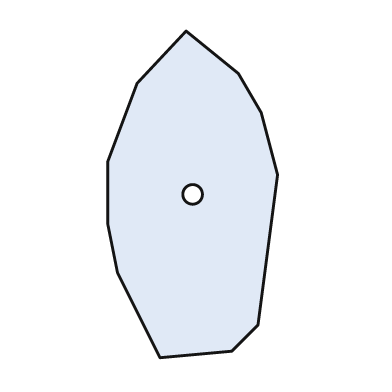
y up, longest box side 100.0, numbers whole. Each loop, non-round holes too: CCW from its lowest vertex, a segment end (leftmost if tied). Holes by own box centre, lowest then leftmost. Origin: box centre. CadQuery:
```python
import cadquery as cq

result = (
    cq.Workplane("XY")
    .moveTo(-10.0, -50.0)
    .lineTo(12.0, -48.0)
    .lineTo(20.0, -40.0)
    .lineTo(26.0, 6.0)
    .lineTo(21.0, 25.0)
    .lineTo(14.0, 37.0)
    .lineTo(-2.0, 50.0)
    .lineTo(-17.0, 34.0)
    .lineTo(-26.0, 10.0)
    .lineTo(-26.0, -9.0)
    .lineTo(-23.0, -24.0)
    .close()
    .moveTo(0.0, 0.0)
    .circle(3.0)
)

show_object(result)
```